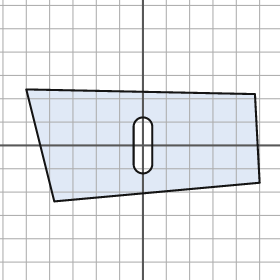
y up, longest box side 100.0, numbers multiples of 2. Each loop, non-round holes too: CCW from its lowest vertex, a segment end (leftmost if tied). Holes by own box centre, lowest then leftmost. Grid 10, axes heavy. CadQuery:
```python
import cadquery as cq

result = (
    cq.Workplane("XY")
    .moveTo(-38.0, -24.0)
    .lineTo(50.0, -16.0)
    .lineTo(48.0, 22.0)
    .lineTo(-50.0, 24.0)
    .close()
    .moveTo(-4.0, -8.0)
    .threePointArc((0.0, -12.0), (4.0, -8.0))
    .lineTo(4.0, 8.0)
    .threePointArc((0.0, 12.0), (-4.0, 8.0))
    .close()
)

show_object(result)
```